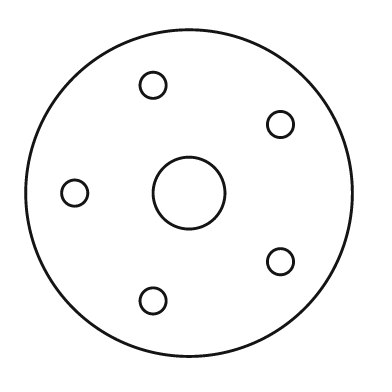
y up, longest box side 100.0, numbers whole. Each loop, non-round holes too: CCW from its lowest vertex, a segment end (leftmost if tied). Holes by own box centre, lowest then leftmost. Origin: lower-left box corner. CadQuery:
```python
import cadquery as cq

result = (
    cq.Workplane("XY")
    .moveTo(50.0, 50.0)
    .circle(50.0)
    .moveTo(39.0, 17.0)
    .circle(4.0)
    .moveTo(78.0, 29.0)
    .circle(4.0)
    .moveTo(15.0, 50.0)
    .circle(4.0)
    .moveTo(50.0, 50.0)
    .circle(11.0)
    .moveTo(78.0, 71.0)
    .circle(4.0)
    .moveTo(39.0, 83.0)
    .circle(4.0)
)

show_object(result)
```